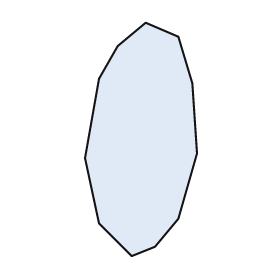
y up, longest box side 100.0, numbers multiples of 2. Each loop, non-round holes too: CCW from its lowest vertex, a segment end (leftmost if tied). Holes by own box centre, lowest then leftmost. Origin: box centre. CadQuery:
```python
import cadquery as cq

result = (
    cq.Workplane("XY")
    .moveTo(-4.0, -50.0)
    .lineTo(6.0, -46.0)
    .lineTo(16.0, -34.0)
    .lineTo(24.0, -6.0)
    .lineTo(22.0, 24.0)
    .lineTo(16.0, 44.0)
    .lineTo(2.0, 50.0)
    .lineTo(-10.0, 40.0)
    .lineTo(-18.0, 26.0)
    .lineTo(-24.0, -8.0)
    .lineTo(-18.0, -36.0)
    .close()
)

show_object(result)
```